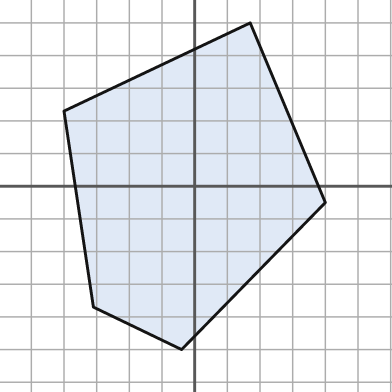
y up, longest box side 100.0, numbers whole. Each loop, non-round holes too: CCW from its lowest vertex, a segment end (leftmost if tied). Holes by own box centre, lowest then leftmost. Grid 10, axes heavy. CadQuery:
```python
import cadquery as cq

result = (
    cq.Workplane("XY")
    .moveTo(-4.0, -50.0)
    .lineTo(40.0, -5.0)
    .lineTo(17.0, 50.0)
    .lineTo(-40.0, 23.0)
    .lineTo(-31.0, -37.0)
    .close()
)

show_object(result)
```